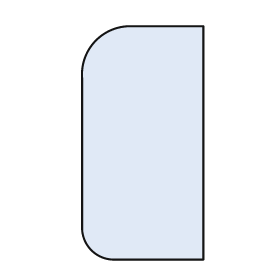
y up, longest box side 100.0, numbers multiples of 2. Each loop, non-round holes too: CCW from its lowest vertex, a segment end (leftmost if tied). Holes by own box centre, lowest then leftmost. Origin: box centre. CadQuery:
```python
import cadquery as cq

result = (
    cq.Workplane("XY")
    .moveTo(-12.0, -50.0)
    .lineTo(26.0, -50.0)
    .lineTo(26.0, 50.0)
    .lineTo(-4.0, 50.0)
    .threePointArc((-20.0, 44.0), (-26.0, 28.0))
    .lineTo(-26.0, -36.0)
    .threePointArc((-22.0, -46.0), (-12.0, -50.0))
    .close()
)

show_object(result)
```